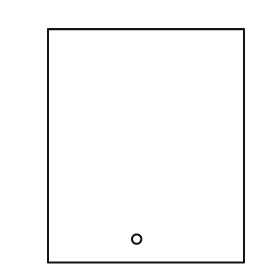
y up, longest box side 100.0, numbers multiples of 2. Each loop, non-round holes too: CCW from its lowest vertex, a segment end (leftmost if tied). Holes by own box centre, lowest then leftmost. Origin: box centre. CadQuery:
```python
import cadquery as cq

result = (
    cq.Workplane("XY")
    .moveTo(-42.0, -50.0)
    .lineTo(42.0, -50.0)
    .lineTo(42.0, 50.0)
    .lineTo(-42.0, 50.0)
    .close()
    .moveTo(-4.0, -40.0)
    .circle(2.0)
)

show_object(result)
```